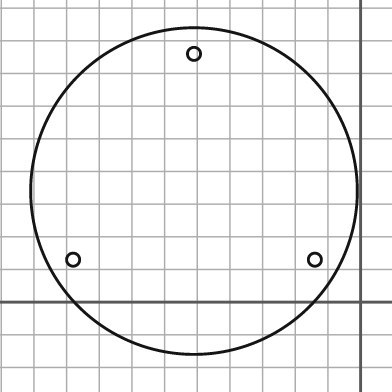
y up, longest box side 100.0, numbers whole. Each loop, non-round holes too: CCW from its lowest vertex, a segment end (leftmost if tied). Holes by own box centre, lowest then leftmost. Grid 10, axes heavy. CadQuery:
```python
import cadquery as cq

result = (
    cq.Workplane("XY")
    .moveTo(-51.0, 34.0)
    .circle(50.0)
    .moveTo(-88.0, 13.0)
    .circle(2.0)
    .moveTo(-14.0, 13.0)
    .circle(2.0)
    .moveTo(-51.0, 76.0)
    .circle(2.0)
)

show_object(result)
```